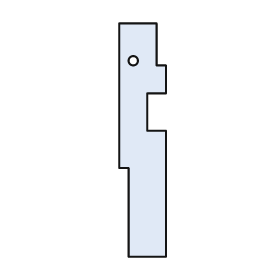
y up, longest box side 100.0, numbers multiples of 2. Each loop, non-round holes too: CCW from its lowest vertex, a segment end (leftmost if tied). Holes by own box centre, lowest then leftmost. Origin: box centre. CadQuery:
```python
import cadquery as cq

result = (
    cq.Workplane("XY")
    .moveTo(-6.0, -50.0)
    .lineTo(10.0, -50.0)
    .lineTo(10.0, 4.0)
    .lineTo(2.0, 4.0)
    .lineTo(2.0, 20.0)
    .lineTo(10.0, 20.0)
    .lineTo(10.0, 32.0)
    .lineTo(6.0, 32.0)
    .lineTo(6.0, 50.0)
    .lineTo(-10.0, 50.0)
    .lineTo(-10.0, -12.0)
    .lineTo(-6.0, -12.0)
    .close()
    .moveTo(-4.0, 34.0)
    .circle(2.0)
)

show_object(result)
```